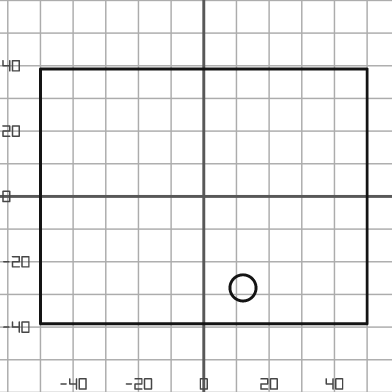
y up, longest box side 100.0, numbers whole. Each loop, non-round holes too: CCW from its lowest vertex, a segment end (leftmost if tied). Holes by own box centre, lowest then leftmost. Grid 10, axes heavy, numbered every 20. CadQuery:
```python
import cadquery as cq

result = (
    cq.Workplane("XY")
    .moveTo(-50.0, -39.0)
    .lineTo(50.0, -39.0)
    .lineTo(50.0, 39.0)
    .lineTo(-50.0, 39.0)
    .close()
    .moveTo(12.0, -28.0)
    .circle(4.0)
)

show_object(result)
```